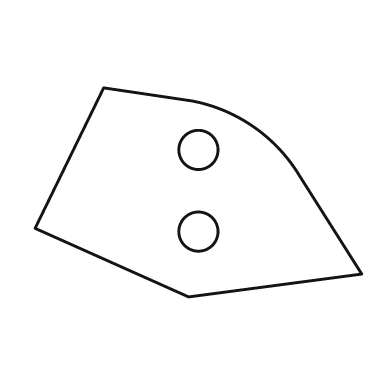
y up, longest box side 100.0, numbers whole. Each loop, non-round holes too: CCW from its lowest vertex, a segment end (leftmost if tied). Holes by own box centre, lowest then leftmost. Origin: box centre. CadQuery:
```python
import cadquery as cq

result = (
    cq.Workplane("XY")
    .moveTo(-3.0, -32.0)
    .lineTo(50.0, -25.0)
    .lineTo(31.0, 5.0)
    .threePointArc((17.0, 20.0), (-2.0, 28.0))
    .lineTo(-29.0, 32.0)
    .lineTo(-50.0, -11.0)
    .close()
    .moveTo(0.0, -12.0)
    .circle(6.0)
    .moveTo(0.0, 13.0)
    .circle(6.0)
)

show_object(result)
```